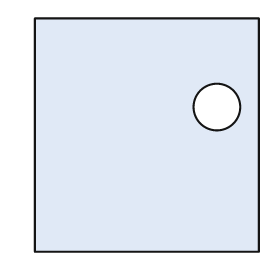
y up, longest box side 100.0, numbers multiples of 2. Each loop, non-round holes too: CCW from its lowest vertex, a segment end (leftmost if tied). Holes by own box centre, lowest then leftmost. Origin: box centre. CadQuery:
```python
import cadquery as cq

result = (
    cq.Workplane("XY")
    .moveTo(-48.0, -50.0)
    .lineTo(48.0, -50.0)
    .lineTo(48.0, 50.0)
    .lineTo(-48.0, 50.0)
    .close()
    .moveTo(30.0, 12.0)
    .circle(10.0)
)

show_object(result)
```